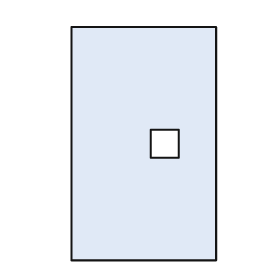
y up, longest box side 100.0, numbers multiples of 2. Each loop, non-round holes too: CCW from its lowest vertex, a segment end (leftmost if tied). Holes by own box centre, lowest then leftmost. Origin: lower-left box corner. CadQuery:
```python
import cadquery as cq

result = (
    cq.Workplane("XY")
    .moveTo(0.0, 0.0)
    .lineTo(62.0, 0.0)
    .lineTo(62.0, 100.0)
    .lineTo(0.0, 100.0)
    .close()
    .moveTo(34.0, 44.0)
    .lineTo(46.0, 44.0)
    .lineTo(46.0, 56.0)
    .lineTo(34.0, 56.0)
    .close()
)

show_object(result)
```